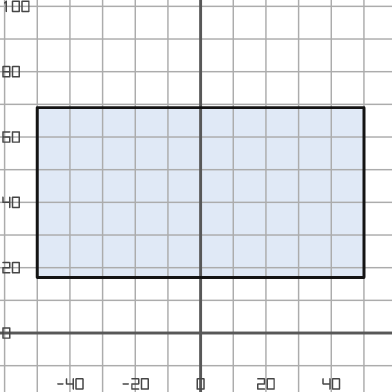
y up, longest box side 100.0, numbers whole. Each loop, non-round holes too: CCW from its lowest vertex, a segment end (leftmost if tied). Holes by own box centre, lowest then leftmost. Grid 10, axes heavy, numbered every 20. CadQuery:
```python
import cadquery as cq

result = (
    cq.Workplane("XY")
    .moveTo(-50.0, 17.0)
    .lineTo(50.0, 17.0)
    .lineTo(50.0, 69.0)
    .lineTo(-50.0, 69.0)
    .close()
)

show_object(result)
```